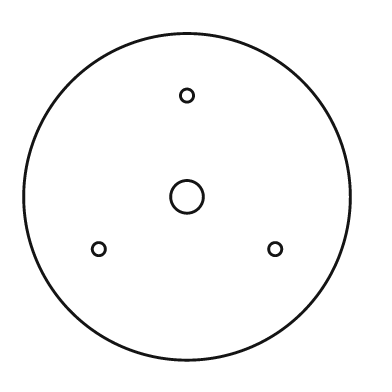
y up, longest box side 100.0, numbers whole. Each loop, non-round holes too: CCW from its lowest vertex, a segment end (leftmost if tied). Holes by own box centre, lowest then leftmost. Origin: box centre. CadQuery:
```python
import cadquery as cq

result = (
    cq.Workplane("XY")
    .moveTo(0.0, 0.0)
    .circle(50.0)
    .moveTo(-27.0, -16.0)
    .circle(2.0)
    .moveTo(27.0, -16.0)
    .circle(2.0)
    .moveTo(0.0, 0.0)
    .circle(5.0)
    .moveTo(0.0, 31.0)
    .circle(2.0)
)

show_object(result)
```